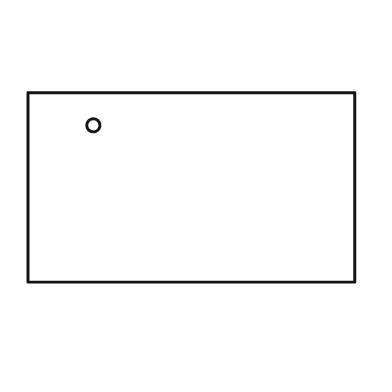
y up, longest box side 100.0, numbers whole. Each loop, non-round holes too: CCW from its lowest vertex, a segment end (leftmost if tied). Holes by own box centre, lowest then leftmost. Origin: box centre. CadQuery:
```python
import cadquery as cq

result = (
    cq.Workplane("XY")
    .moveTo(-50.0, -29.0)
    .lineTo(50.0, -29.0)
    .lineTo(50.0, 29.0)
    .lineTo(-50.0, 29.0)
    .close()
    .moveTo(-30.0, 19.0)
    .circle(2.0)
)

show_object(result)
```